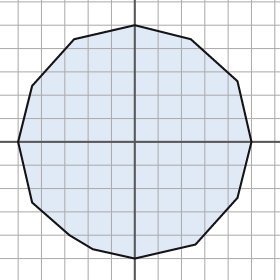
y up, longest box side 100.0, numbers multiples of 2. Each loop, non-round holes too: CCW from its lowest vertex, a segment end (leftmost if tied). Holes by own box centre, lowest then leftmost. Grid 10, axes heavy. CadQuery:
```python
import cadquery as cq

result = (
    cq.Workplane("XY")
    .moveTo(0.0, -50.0)
    .lineTo(26.0, -44.0)
    .lineTo(44.0, -24.0)
    .lineTo(50.0, 0.0)
    .lineTo(44.0, 26.0)
    .lineTo(24.0, 44.0)
    .lineTo(0.0, 50.0)
    .lineTo(-26.0, 44.0)
    .lineTo(-44.0, 24.0)
    .lineTo(-50.0, 0.0)
    .lineTo(-44.0, -26.0)
    .lineTo(-28.0, -40.0)
    .lineTo(-18.0, -46.0)
    .close()
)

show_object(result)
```